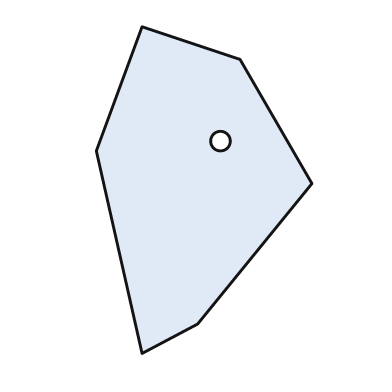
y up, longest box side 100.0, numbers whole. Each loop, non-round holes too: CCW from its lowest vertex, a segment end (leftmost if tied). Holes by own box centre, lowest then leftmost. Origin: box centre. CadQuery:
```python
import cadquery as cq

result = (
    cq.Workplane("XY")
    .moveTo(-19.0, -50.0)
    .lineTo(-2.0, -41.0)
    .lineTo(33.0, 2.0)
    .lineTo(11.0, 40.0)
    .lineTo(-19.0, 50.0)
    .lineTo(-33.0, 12.0)
    .close()
    .moveTo(5.0, 15.0)
    .circle(3.0)
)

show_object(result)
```